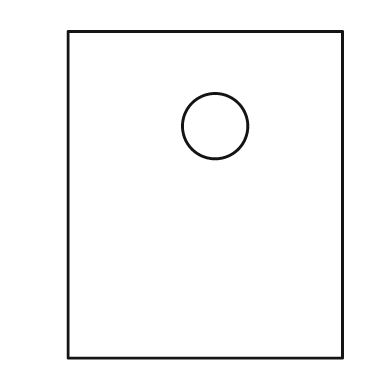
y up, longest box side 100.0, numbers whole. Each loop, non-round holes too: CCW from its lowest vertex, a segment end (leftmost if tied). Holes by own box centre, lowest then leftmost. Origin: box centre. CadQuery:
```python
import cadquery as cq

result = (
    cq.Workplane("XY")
    .moveTo(-42.0, -50.0)
    .lineTo(42.0, -50.0)
    .lineTo(42.0, 50.0)
    .lineTo(-42.0, 50.0)
    .close()
    .moveTo(3.0, 21.0)
    .circle(10.0)
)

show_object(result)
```